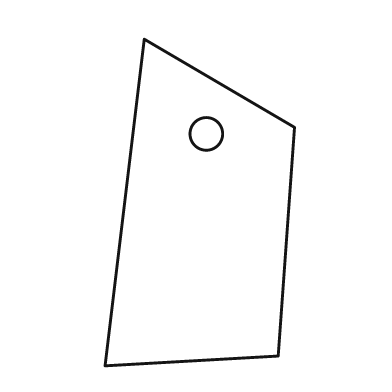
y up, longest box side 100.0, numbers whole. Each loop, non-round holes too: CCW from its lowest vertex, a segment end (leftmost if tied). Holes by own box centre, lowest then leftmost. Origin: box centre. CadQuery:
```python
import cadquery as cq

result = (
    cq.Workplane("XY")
    .moveTo(-29.0, -50.0)
    .lineTo(24.0, -47.0)
    .lineTo(29.0, 23.0)
    .lineTo(-17.0, 50.0)
    .close()
    .moveTo(2.0, 21.0)
    .circle(5.0)
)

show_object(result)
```